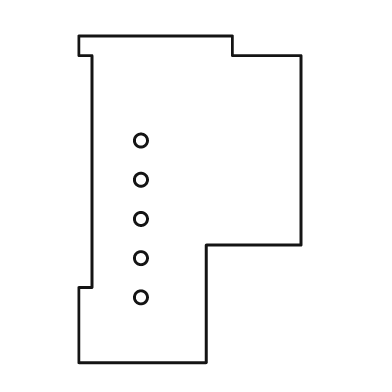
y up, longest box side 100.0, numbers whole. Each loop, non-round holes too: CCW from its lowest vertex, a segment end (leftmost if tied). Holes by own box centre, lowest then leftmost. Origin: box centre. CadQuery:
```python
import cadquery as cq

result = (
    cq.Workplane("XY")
    .moveTo(-34.0, -50.0)
    .lineTo(5.0, -50.0)
    .lineTo(5.0, -14.0)
    .lineTo(34.0, -14.0)
    .lineTo(34.0, 44.0)
    .lineTo(13.0, 44.0)
    .lineTo(13.0, 50.0)
    .lineTo(-34.0, 50.0)
    .lineTo(-34.0, 44.0)
    .lineTo(-30.0, 44.0)
    .lineTo(-30.0, -27.0)
    .lineTo(-34.0, -27.0)
    .close()
    .moveTo(-15.0, -30.0)
    .circle(2.0)
    .moveTo(-15.0, -18.0)
    .circle(2.0)
    .moveTo(-15.0, -6.0)
    .circle(2.0)
    .moveTo(-15.0, 6.0)
    .circle(2.0)
    .moveTo(-15.0, 18.0)
    .circle(2.0)
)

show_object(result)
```